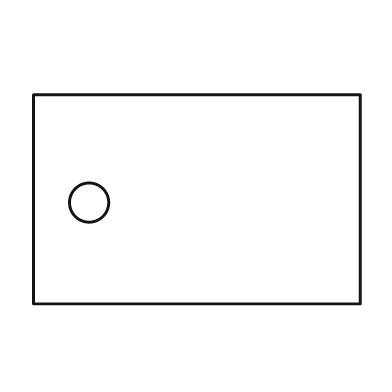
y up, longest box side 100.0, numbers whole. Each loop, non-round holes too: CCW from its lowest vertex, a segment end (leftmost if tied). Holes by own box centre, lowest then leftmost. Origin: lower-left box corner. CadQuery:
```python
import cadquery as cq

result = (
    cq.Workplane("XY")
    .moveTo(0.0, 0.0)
    .lineTo(100.0, 0.0)
    .lineTo(100.0, 64.0)
    .lineTo(0.0, 64.0)
    .close()
    .moveTo(17.0, 31.0)
    .circle(6.0)
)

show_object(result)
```